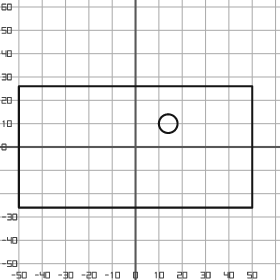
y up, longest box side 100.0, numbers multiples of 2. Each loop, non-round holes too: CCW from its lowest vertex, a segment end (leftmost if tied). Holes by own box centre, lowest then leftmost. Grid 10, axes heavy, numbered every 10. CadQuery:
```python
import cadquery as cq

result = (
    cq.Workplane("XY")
    .moveTo(-50.0, -26.0)
    .lineTo(50.0, -26.0)
    .lineTo(50.0, 26.0)
    .lineTo(-50.0, 26.0)
    .close()
    .moveTo(14.0, 10.0)
    .circle(4.0)
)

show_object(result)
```